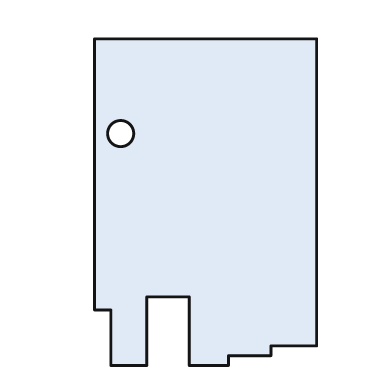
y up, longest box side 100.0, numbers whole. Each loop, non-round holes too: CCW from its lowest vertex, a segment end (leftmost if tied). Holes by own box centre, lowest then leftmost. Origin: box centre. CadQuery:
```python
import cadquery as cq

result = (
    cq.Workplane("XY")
    .moveTo(-29.0, -50.0)
    .lineTo(-18.0, -50.0)
    .lineTo(-18.0, -29.0)
    .lineTo(-5.0, -29.0)
    .lineTo(-5.0, -50.0)
    .lineTo(7.0, -50.0)
    .lineTo(7.0, -47.0)
    .lineTo(20.0, -47.0)
    .lineTo(20.0, -44.0)
    .lineTo(34.0, -44.0)
    .lineTo(34.0, 50.0)
    .lineTo(-34.0, 50.0)
    .lineTo(-34.0, -33.0)
    .lineTo(-29.0, -33.0)
    .close()
    .moveTo(-26.0, 21.0)
    .circle(4.0)
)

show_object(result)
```